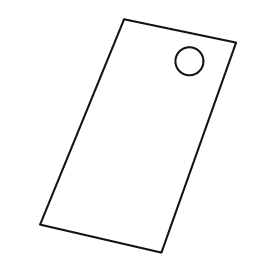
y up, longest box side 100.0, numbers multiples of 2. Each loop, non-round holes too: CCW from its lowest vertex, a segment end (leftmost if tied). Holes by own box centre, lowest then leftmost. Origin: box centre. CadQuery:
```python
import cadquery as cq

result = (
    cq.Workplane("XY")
    .moveTo(10.0, -50.0)
    .lineTo(42.0, 40.0)
    .lineTo(-6.0, 50.0)
    .lineTo(-42.0, -38.0)
    .close()
    .moveTo(22.0, 32.0)
    .circle(6.0)
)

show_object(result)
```